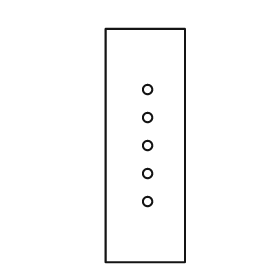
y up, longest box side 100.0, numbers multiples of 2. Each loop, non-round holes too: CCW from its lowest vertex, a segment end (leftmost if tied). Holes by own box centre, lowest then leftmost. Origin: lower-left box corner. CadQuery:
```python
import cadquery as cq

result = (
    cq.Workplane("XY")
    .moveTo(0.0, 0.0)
    .lineTo(34.0, 0.0)
    .lineTo(34.0, 100.0)
    .lineTo(0.0, 100.0)
    .close()
    .moveTo(18.0, 26.0)
    .circle(2.0)
    .moveTo(18.0, 38.0)
    .circle(2.0)
    .moveTo(18.0, 50.0)
    .circle(2.0)
    .moveTo(18.0, 62.0)
    .circle(2.0)
    .moveTo(18.0, 74.0)
    .circle(2.0)
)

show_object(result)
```